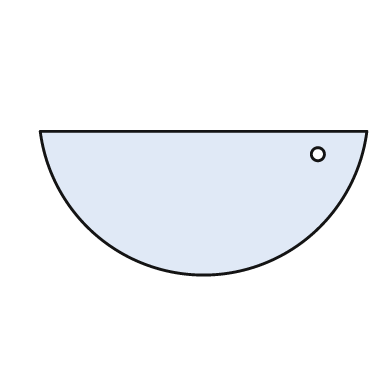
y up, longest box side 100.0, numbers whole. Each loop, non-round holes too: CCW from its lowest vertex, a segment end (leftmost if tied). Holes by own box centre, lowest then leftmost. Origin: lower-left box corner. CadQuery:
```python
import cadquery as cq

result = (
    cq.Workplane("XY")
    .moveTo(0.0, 44.0)
    .threePointArc((50.0, 0.0), (100.0, 44.0))
    .close()
    .moveTo(85.0, 37.0)
    .circle(2.0)
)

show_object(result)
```